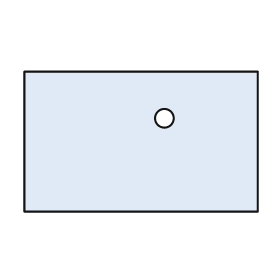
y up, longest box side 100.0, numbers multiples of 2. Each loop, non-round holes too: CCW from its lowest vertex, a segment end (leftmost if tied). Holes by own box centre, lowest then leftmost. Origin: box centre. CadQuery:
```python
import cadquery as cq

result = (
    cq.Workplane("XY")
    .moveTo(-50.0, -30.0)
    .lineTo(50.0, -30.0)
    .lineTo(50.0, 30.0)
    .lineTo(-50.0, 30.0)
    .close()
    .moveTo(10.0, 10.0)
    .circle(4.0)
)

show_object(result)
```